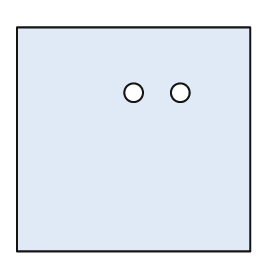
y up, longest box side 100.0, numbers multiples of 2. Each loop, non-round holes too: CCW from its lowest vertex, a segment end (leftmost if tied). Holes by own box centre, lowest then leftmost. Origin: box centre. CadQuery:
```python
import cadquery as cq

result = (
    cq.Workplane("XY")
    .moveTo(-50.0, -48.0)
    .lineTo(50.0, -48.0)
    .lineTo(50.0, 48.0)
    .lineTo(-50.0, 48.0)
    .close()
    .moveTo(0.0, 20.0)
    .circle(4.0)
    .moveTo(20.0, 20.0)
    .circle(4.0)
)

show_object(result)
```